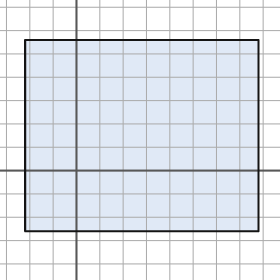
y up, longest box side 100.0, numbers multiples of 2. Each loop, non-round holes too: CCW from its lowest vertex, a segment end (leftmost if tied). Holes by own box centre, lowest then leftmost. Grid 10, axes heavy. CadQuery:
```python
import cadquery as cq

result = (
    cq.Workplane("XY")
    .moveTo(-22.0, -26.0)
    .lineTo(78.0, -26.0)
    .lineTo(78.0, 56.0)
    .lineTo(-22.0, 56.0)
    .close()
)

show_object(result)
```